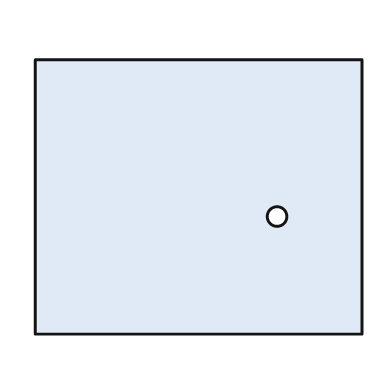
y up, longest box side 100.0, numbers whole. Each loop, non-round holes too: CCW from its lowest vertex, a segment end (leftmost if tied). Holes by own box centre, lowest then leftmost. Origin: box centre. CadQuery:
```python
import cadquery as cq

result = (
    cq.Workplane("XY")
    .moveTo(-50.0, -42.0)
    .lineTo(50.0, -42.0)
    .lineTo(50.0, 42.0)
    .lineTo(-50.0, 42.0)
    .close()
    .moveTo(24.0, -6.0)
    .circle(3.0)
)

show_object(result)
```